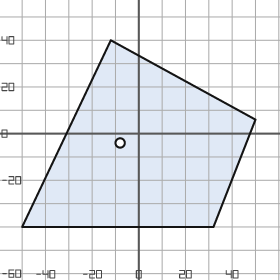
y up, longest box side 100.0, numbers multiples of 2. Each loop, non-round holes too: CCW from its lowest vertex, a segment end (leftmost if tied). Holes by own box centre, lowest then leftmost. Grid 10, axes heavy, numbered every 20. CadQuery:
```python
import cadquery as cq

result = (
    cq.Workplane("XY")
    .moveTo(-50.0, -40.0)
    .lineTo(32.0, -40.0)
    .lineTo(50.0, 6.0)
    .lineTo(-12.0, 40.0)
    .close()
    .moveTo(-8.0, -4.0)
    .circle(2.0)
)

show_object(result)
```